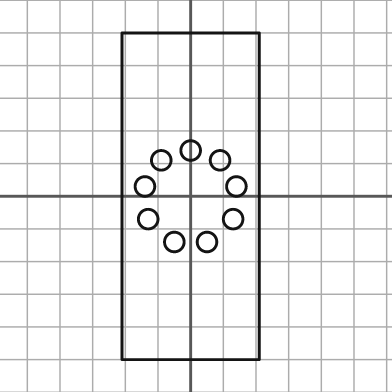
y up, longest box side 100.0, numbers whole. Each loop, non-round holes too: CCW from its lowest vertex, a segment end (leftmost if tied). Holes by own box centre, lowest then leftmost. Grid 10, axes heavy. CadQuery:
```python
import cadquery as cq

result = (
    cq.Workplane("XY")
    .moveTo(-21.0, -50.0)
    .lineTo(21.0, -50.0)
    .lineTo(21.0, 50.0)
    .lineTo(-21.0, 50.0)
    .close()
    .moveTo(-5.0, -14.0)
    .circle(3.0)
    .moveTo(5.0, -14.0)
    .circle(3.0)
    .moveTo(-13.0, -7.0)
    .circle(3.0)
    .moveTo(13.0, -7.0)
    .circle(3.0)
    .moveTo(-14.0, 3.0)
    .circle(3.0)
    .moveTo(14.0, 3.0)
    .circle(3.0)
    .moveTo(-9.0, 11.0)
    .circle(3.0)
    .moveTo(9.0, 11.0)
    .circle(3.0)
    .moveTo(0.0, 14.0)
    .circle(3.0)
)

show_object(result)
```